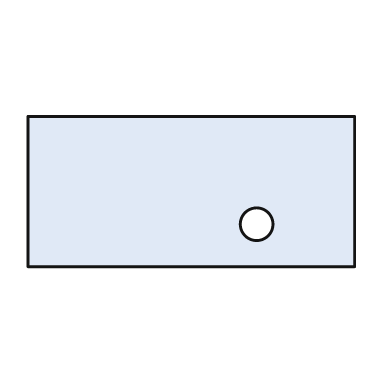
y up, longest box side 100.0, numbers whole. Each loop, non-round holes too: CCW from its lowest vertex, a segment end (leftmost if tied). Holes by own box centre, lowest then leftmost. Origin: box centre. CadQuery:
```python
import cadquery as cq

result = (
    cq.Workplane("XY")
    .moveTo(-50.0, -23.0)
    .lineTo(50.0, -23.0)
    .lineTo(50.0, 23.0)
    .lineTo(-50.0, 23.0)
    .close()
    .moveTo(20.0, -10.0)
    .circle(5.0)
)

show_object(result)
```